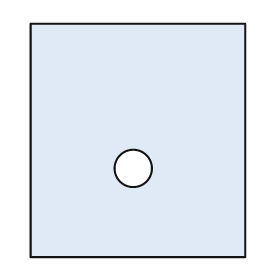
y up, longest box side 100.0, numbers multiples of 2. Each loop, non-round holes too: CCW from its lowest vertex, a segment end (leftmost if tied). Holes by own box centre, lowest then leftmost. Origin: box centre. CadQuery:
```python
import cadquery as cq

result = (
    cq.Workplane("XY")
    .moveTo(-46.0, -50.0)
    .lineTo(46.0, -50.0)
    .lineTo(46.0, 50.0)
    .lineTo(-46.0, 50.0)
    .close()
    .moveTo(-2.0, -12.0)
    .circle(8.0)
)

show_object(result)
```